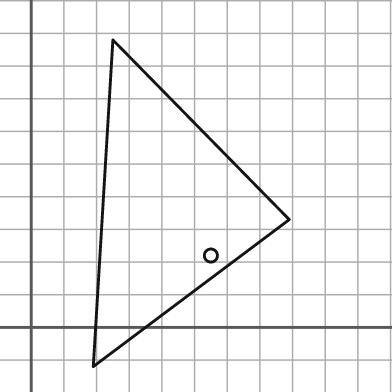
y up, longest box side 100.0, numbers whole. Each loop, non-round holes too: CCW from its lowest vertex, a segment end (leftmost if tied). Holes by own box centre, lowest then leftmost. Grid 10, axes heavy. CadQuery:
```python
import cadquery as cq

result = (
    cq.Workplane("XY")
    .moveTo(19.0, -12.0)
    .lineTo(79.0, 33.0)
    .lineTo(25.0, 88.0)
    .close()
    .moveTo(55.0, 22.0)
    .circle(2.0)
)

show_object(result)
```